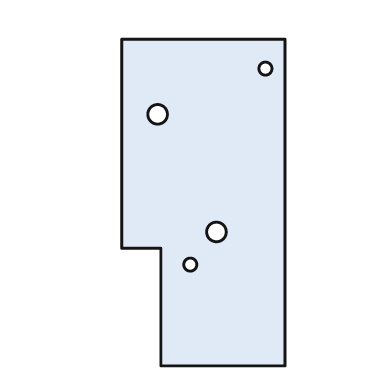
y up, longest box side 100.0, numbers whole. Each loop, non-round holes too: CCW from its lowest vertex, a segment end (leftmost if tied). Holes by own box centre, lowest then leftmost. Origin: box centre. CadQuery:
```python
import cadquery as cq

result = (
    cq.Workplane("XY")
    .moveTo(-13.0, -50.0)
    .lineTo(25.0, -50.0)
    .lineTo(25.0, 50.0)
    .lineTo(-25.0, 50.0)
    .lineTo(-25.0, -14.0)
    .lineTo(-13.0, -14.0)
    .close()
    .moveTo(-4.0, -19.0)
    .circle(2.0)
    .moveTo(4.0, -9.0)
    .circle(3.0)
    .moveTo(-14.0, 27.0)
    .circle(3.0)
    .moveTo(19.0, 41.0)
    .circle(2.0)
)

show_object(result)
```